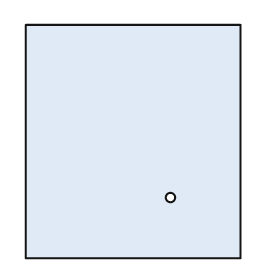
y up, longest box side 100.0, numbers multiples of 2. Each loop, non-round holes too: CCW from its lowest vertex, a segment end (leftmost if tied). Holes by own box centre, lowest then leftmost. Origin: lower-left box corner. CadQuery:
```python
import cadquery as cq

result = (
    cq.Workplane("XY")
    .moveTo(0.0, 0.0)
    .lineTo(92.0, 0.0)
    .lineTo(92.0, 100.0)
    .lineTo(0.0, 100.0)
    .close()
    .moveTo(62.0, 26.0)
    .circle(2.0)
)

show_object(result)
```